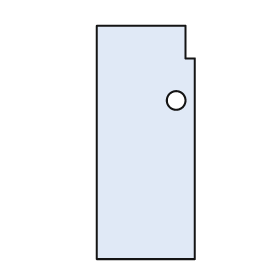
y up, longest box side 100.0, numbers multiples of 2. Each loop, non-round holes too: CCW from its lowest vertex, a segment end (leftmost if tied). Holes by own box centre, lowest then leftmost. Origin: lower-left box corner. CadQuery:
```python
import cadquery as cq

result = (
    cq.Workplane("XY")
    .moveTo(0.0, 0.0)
    .lineTo(42.0, 0.0)
    .lineTo(42.0, 86.0)
    .lineTo(38.0, 86.0)
    .lineTo(38.0, 100.0)
    .lineTo(0.0, 100.0)
    .close()
    .moveTo(34.0, 68.0)
    .circle(4.0)
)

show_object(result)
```